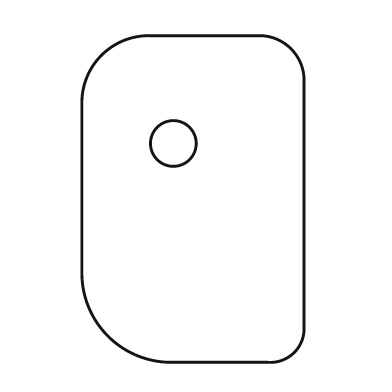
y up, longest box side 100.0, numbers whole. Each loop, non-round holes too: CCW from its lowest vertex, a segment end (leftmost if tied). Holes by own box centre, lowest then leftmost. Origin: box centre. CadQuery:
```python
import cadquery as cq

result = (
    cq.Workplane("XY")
    .moveTo(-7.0, -50.0)
    .lineTo(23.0, -50.0)
    .threePointArc((31.0, -47.0), (34.0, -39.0))
    .lineTo(34.0, 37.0)
    .threePointArc((30.0, 46.0), (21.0, 50.0))
    .lineTo(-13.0, 50.0)
    .threePointArc((-28.0, 44.0), (-34.0, 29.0))
    .lineTo(-34.0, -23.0)
    .threePointArc((-26.0, -42.0), (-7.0, -50.0))
    .close()
    .moveTo(-6.0, 17.0)
    .circle(7.0)
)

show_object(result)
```